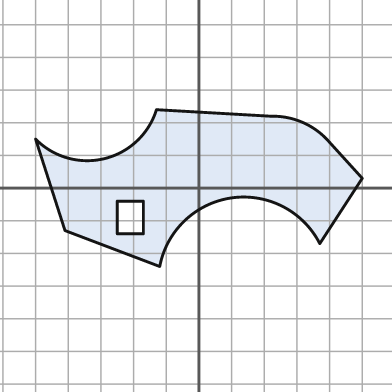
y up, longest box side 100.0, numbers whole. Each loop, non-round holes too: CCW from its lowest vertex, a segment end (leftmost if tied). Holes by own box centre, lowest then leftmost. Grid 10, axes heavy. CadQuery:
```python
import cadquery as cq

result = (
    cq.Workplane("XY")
    .moveTo(-12.0, -24.0)
    .threePointArc((10.0, -3.0), (37.0, -17.0))
    .lineTo(50.0, 3.0)
    .lineTo(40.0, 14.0)
    .threePointArc((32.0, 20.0), (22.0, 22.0))
    .lineTo(-13.0, 24.0)
    .threePointArc((-29.0, 9.0), (-50.0, 15.0))
    .lineTo(-41.0, -13.0)
    .close()
    .moveTo(-25.0, -14.0)
    .lineTo(-17.0, -14.0)
    .lineTo(-17.0, -4.0)
    .lineTo(-25.0, -4.0)
    .close()
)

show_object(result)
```